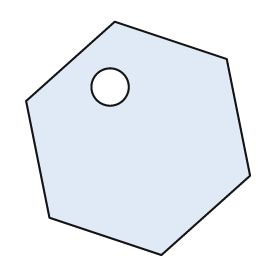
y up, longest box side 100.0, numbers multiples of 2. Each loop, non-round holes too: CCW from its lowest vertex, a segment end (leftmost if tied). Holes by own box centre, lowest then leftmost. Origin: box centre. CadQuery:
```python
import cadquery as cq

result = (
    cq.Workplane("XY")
    .moveTo(10.0, -50.0)
    .lineTo(48.0, -16.0)
    .lineTo(38.0, 34.0)
    .lineTo(-10.0, 50.0)
    .lineTo(-48.0, 16.0)
    .lineTo(-38.0, -34.0)
    .close()
    .moveTo(-12.0, 22.0)
    .circle(8.0)
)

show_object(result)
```